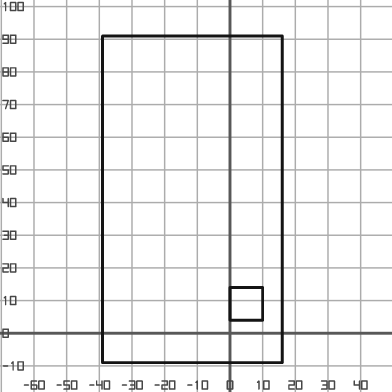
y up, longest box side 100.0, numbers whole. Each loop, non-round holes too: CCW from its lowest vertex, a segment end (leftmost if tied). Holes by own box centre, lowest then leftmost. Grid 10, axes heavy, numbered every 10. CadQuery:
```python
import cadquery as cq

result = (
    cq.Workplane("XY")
    .moveTo(-39.0, -9.0)
    .lineTo(16.0, -9.0)
    .lineTo(16.0, 91.0)
    .lineTo(-39.0, 91.0)
    .close()
    .moveTo(0.0, 4.0)
    .lineTo(10.0, 4.0)
    .lineTo(10.0, 14.0)
    .lineTo(0.0, 14.0)
    .close()
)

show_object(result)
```